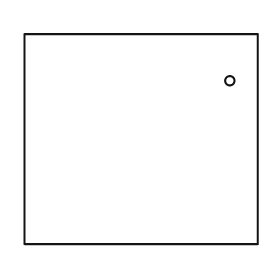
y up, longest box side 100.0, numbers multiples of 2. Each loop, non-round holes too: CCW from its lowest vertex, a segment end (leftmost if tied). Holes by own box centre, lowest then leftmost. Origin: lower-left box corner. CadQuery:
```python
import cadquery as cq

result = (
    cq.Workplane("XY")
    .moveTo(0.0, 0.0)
    .lineTo(100.0, 0.0)
    .lineTo(100.0, 90.0)
    .lineTo(0.0, 90.0)
    .close()
    .moveTo(88.0, 70.0)
    .circle(2.0)
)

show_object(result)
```